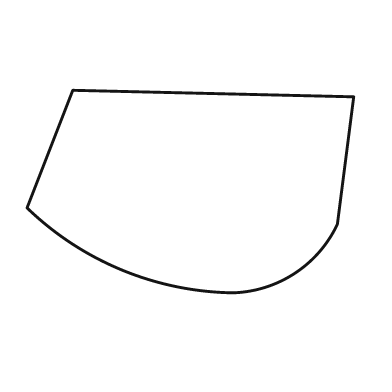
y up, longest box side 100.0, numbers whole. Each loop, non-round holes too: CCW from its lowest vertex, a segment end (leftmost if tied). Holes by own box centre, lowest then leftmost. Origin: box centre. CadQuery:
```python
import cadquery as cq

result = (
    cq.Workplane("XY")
    .moveTo(13.0, -31.0)
    .threePointArc((32.0, -25.0), (45.0, -10.0))
    .lineTo(50.0, 29.0)
    .lineTo(-36.0, 31.0)
    .lineTo(-50.0, -5.0)
    .threePointArc((-21.0, -24.0), (13.0, -31.0))
    .close()
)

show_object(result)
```